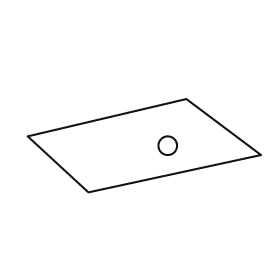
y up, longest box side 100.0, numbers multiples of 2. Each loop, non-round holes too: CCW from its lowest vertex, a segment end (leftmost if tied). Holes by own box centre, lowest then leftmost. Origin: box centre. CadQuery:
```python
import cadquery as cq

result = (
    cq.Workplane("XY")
    .moveTo(-24.0, -20.0)
    .lineTo(50.0, -4.0)
    .lineTo(18.0, 20.0)
    .lineTo(-50.0, 4.0)
    .close()
    .moveTo(10.0, 0.0)
    .circle(4.0)
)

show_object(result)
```